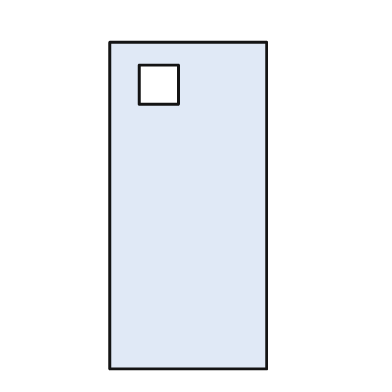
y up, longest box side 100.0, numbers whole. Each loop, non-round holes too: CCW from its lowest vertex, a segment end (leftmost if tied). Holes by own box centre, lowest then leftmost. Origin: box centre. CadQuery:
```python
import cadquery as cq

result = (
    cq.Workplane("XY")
    .moveTo(-24.0, -50.0)
    .lineTo(24.0, -50.0)
    .lineTo(24.0, 50.0)
    .lineTo(-24.0, 50.0)
    .close()
    .moveTo(-15.0, 31.0)
    .lineTo(-3.0, 31.0)
    .lineTo(-3.0, 43.0)
    .lineTo(-15.0, 43.0)
    .close()
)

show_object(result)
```